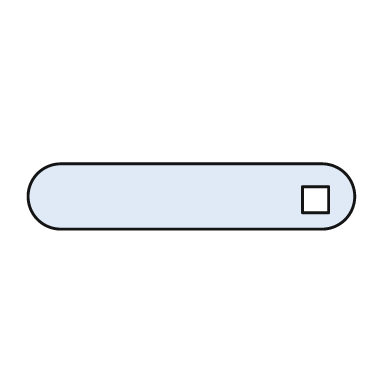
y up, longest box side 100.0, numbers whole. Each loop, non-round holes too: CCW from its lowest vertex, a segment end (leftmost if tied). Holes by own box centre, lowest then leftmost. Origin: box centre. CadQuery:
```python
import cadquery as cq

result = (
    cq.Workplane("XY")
    .moveTo(-40.0, -10.0)
    .lineTo(40.0, -10.0)
    .threePointArc((50.0, 0.0), (40.0, 10.0))
    .lineTo(-40.0, 10.0)
    .threePointArc((-50.0, 0.0), (-40.0, -10.0))
    .close()
    .moveTo(34.0, -5.0)
    .lineTo(42.0, -5.0)
    .lineTo(42.0, 3.0)
    .lineTo(34.0, 3.0)
    .close()
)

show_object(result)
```